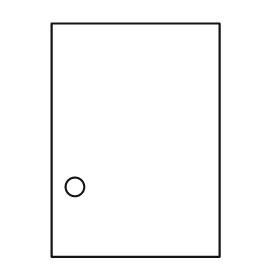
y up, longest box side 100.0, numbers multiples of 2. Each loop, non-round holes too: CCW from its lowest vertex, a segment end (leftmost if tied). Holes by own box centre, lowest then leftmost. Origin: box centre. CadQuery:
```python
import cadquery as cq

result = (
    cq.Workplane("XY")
    .moveTo(-36.0, -50.0)
    .lineTo(36.0, -50.0)
    .lineTo(36.0, 50.0)
    .lineTo(-36.0, 50.0)
    .close()
    .moveTo(-26.0, -20.0)
    .circle(4.0)
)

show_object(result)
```